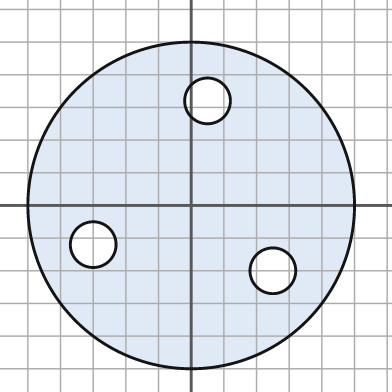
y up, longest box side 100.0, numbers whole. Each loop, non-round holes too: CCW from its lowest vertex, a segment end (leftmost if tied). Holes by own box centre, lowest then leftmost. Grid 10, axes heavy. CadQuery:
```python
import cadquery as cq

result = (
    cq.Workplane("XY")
    .moveTo(0.0, 0.0)
    .circle(50.0)
    .moveTo(25.0, -20.0)
    .circle(7.0)
    .moveTo(-30.0, -12.0)
    .circle(7.0)
    .moveTo(5.0, 32.0)
    .circle(7.0)
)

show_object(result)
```